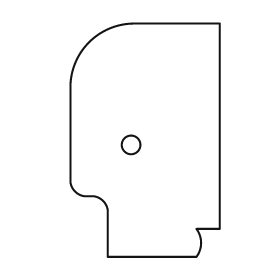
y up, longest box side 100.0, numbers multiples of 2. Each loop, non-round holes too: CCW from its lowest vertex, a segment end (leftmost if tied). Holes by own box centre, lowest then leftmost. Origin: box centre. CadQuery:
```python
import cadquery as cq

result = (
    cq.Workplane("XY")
    .moveTo(-16.0, -50.0)
    .lineTo(22.0, -50.0)
    .threePointArc((24.0, -44.0), (22.0, -38.0))
    .lineTo(32.0, -38.0)
    .lineTo(32.0, 50.0)
    .lineTo(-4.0, 50.0)
    .threePointArc((-24.0, 42.0), (-32.0, 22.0))
    .lineTo(-32.0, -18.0)
    .threePointArc((-30.0, -22.0), (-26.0, -24.0))
    .lineTo(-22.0, -24.0)
    .threePointArc((-18.0, -26.0), (-16.0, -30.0))
    .close()
    .moveTo(-6.0, -2.0)
    .circle(4.0)
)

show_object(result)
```